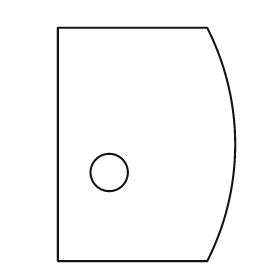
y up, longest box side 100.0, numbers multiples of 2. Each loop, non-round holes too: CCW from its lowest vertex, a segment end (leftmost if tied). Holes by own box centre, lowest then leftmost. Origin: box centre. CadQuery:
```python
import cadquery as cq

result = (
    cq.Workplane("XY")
    .moveTo(-38.0, -50.0)
    .lineTo(26.0, -50.0)
    .threePointArc((38.0, 0.0), (26.0, 50.0))
    .lineTo(-38.0, 50.0)
    .close()
    .moveTo(-16.0, -12.0)
    .circle(8.0)
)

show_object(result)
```